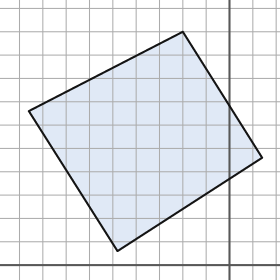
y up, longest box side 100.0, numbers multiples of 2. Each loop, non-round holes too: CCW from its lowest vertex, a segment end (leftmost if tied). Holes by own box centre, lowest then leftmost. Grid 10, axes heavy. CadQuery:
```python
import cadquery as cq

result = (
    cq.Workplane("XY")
    .moveTo(-48.0, 6.0)
    .lineTo(14.0, 46.0)
    .lineTo(-20.0, 100.0)
    .lineTo(-86.0, 66.0)
    .close()
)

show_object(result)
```